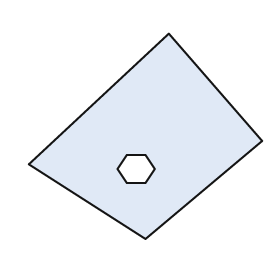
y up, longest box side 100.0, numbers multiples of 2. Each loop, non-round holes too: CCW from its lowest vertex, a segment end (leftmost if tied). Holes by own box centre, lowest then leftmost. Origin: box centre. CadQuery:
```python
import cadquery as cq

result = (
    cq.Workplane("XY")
    .moveTo(0.0, -44.0)
    .lineTo(50.0, -2.0)
    .lineTo(10.0, 44.0)
    .lineTo(-50.0, -12.0)
    .close()
    .moveTo(-8.0, -20.0)
    .lineTo(0.0, -20.0)
    .lineTo(4.0, -14.0)
    .lineTo(0.0, -8.0)
    .lineTo(-8.0, -8.0)
    .lineTo(-12.0, -14.0)
    .close()
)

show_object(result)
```